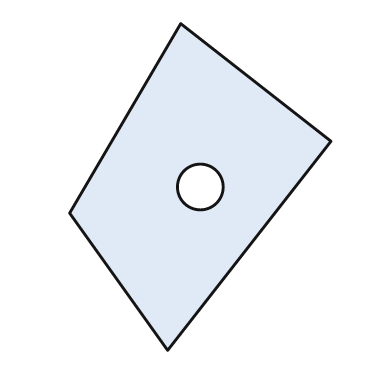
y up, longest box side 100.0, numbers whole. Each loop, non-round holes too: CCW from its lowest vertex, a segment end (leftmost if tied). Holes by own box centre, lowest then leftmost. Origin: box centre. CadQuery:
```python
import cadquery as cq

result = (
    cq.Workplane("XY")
    .moveTo(-10.0, -50.0)
    .lineTo(40.0, 14.0)
    .lineTo(-6.0, 50.0)
    .lineTo(-40.0, -8.0)
    .close()
    .moveTo(0.0, 0.0)
    .circle(7.0)
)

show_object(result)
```